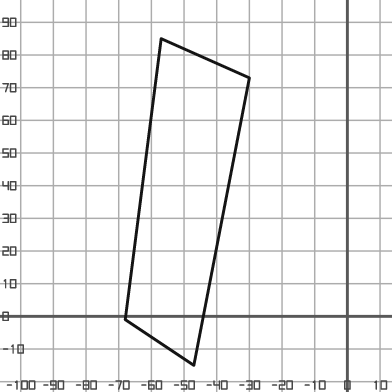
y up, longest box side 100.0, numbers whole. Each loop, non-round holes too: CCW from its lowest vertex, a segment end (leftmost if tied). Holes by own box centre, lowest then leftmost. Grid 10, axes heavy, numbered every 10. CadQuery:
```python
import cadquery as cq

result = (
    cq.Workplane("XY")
    .moveTo(-47.0, -15.0)
    .lineTo(-30.0, 73.0)
    .lineTo(-57.0, 85.0)
    .lineTo(-68.0, -1.0)
    .close()
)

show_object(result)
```